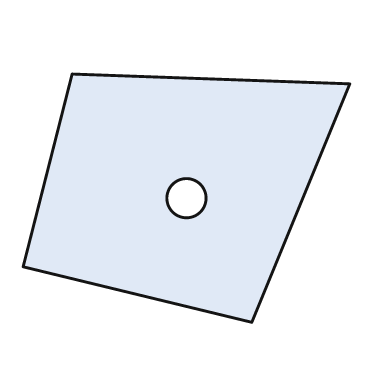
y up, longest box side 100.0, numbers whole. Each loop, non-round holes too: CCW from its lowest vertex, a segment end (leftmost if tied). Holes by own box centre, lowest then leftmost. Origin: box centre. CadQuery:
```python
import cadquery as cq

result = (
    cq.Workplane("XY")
    .moveTo(20.0, -38.0)
    .lineTo(50.0, 35.0)
    .lineTo(-35.0, 38.0)
    .lineTo(-50.0, -21.0)
    .close()
    .moveTo(0.0, 0.0)
    .circle(6.0)
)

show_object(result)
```